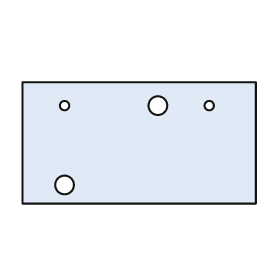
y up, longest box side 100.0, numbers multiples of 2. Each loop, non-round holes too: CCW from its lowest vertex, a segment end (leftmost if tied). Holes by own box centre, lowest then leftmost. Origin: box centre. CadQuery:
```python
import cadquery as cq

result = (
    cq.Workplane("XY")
    .moveTo(-50.0, -26.0)
    .lineTo(50.0, -26.0)
    .lineTo(50.0, 26.0)
    .lineTo(-50.0, 26.0)
    .close()
    .moveTo(-32.0, -18.0)
    .circle(4.0)
    .moveTo(-32.0, 16.0)
    .circle(2.0)
    .moveTo(8.0, 16.0)
    .circle(4.0)
    .moveTo(30.0, 16.0)
    .circle(2.0)
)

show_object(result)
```